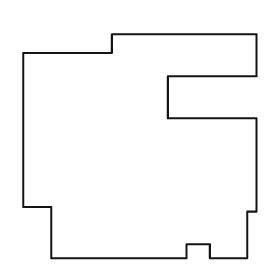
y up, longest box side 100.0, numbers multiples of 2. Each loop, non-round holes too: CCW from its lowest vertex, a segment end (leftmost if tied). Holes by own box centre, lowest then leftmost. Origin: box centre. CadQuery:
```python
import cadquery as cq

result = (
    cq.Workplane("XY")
    .moveTo(-38.0, -48.0)
    .lineTo(20.0, -48.0)
    .lineTo(20.0, -42.0)
    .lineTo(30.0, -42.0)
    .lineTo(30.0, -48.0)
    .lineTo(46.0, -48.0)
    .lineTo(46.0, -28.0)
    .lineTo(50.0, -28.0)
    .lineTo(50.0, 12.0)
    .lineTo(12.0, 12.0)
    .lineTo(12.0, 30.0)
    .lineTo(50.0, 30.0)
    .lineTo(50.0, 48.0)
    .lineTo(-12.0, 48.0)
    .lineTo(-12.0, 40.0)
    .lineTo(-50.0, 40.0)
    .lineTo(-50.0, -26.0)
    .lineTo(-38.0, -26.0)
    .close()
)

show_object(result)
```